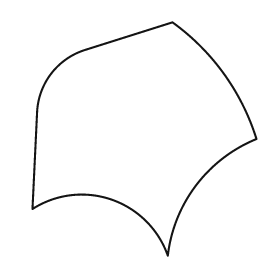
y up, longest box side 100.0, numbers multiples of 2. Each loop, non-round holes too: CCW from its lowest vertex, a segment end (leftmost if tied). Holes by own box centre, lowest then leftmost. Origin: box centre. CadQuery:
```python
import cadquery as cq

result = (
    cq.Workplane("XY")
    .moveTo(10.0, -50.0)
    .threePointArc((22.0, -20.0), (48.0, 0.0))
    .threePointArc((34.0, 28.0), (12.0, 50.0))
    .lineTo(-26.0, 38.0)
    .threePointArc((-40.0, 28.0), (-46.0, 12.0))
    .lineTo(-48.0, -30.0)
    .threePointArc((-14.0, -26.0), (10.0, -50.0))
    .close()
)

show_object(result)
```